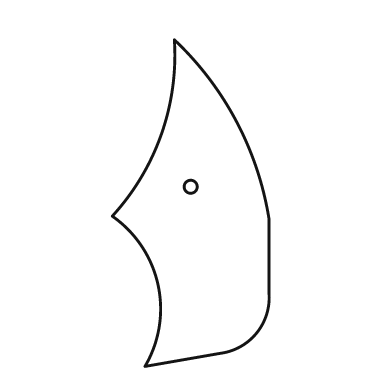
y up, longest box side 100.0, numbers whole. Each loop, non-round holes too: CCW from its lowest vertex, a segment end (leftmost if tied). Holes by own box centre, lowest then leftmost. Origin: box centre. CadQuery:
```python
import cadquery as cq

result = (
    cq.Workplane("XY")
    .moveTo(-14.0, -50.0)
    .lineTo(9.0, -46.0)
    .threePointArc((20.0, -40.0), (24.0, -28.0))
    .lineTo(24.0, -5.0)
    .threePointArc((14.0, 25.0), (-5.0, 50.0))
    .threePointArc((-9.0, 21.0), (-24.0, -4.0))
    .threePointArc((-10.0, -25.0), (-14.0, -50.0))
    .close()
    .moveTo(0.0, 5.0)
    .circle(2.0)
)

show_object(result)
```